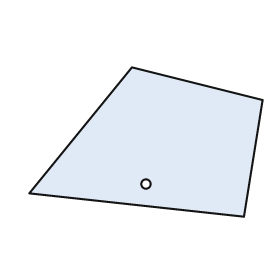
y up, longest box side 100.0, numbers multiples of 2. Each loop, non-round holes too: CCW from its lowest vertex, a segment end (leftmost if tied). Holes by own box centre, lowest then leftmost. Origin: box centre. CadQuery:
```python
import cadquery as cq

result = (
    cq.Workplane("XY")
    .moveTo(42.0, -32.0)
    .lineTo(50.0, 18.0)
    .lineTo(-6.0, 32.0)
    .lineTo(-50.0, -22.0)
    .close()
    .moveTo(0.0, -18.0)
    .circle(2.0)
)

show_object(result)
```